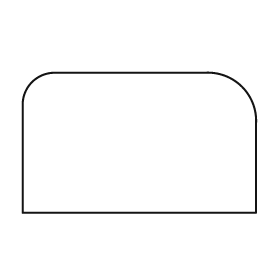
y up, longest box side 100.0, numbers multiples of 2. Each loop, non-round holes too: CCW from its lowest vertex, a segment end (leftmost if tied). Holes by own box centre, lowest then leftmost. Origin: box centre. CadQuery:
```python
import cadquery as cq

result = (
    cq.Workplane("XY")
    .moveTo(-50.0, -30.0)
    .lineTo(50.0, -30.0)
    .lineTo(50.0, 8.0)
    .threePointArc((44.0, 24.0), (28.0, 30.0))
    .lineTo(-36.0, 30.0)
    .threePointArc((-46.0, 26.0), (-50.0, 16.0))
    .close()
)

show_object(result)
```